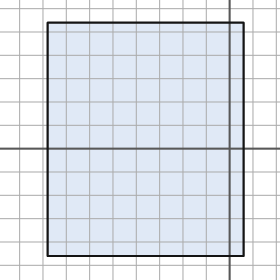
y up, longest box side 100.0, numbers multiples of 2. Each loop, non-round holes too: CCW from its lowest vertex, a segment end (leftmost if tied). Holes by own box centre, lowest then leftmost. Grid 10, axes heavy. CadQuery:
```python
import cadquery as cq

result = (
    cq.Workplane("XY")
    .moveTo(-78.0, -46.0)
    .lineTo(6.0, -46.0)
    .lineTo(6.0, 54.0)
    .lineTo(-78.0, 54.0)
    .close()
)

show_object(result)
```